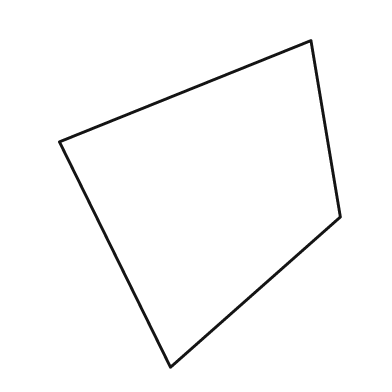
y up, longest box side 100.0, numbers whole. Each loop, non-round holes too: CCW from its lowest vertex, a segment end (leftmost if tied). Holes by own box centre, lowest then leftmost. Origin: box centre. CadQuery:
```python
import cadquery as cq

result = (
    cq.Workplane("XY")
    .moveTo(-9.0, -50.0)
    .lineTo(43.0, -4.0)
    .lineTo(34.0, 50.0)
    .lineTo(-43.0, 19.0)
    .close()
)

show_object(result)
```